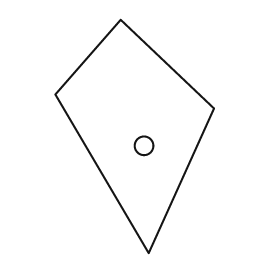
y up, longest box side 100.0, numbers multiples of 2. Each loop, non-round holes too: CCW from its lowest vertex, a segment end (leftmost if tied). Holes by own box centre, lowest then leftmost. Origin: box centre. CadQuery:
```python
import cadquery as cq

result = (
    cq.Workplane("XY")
    .moveTo(6.0, -50.0)
    .lineTo(34.0, 12.0)
    .lineTo(-6.0, 50.0)
    .lineTo(-34.0, 18.0)
    .close()
    .moveTo(4.0, -4.0)
    .circle(4.0)
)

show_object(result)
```